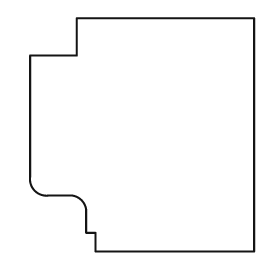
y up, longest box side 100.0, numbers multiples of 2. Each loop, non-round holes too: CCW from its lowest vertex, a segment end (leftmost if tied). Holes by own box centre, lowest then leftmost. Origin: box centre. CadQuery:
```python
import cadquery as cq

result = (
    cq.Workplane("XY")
    .moveTo(-20.0, -50.0)
    .lineTo(48.0, -50.0)
    .lineTo(48.0, 50.0)
    .lineTo(-28.0, 50.0)
    .lineTo(-28.0, 34.0)
    .lineTo(-48.0, 34.0)
    .lineTo(-48.0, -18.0)
    .threePointArc((-46.0, -24.0), (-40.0, -26.0))
    .lineTo(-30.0, -26.0)
    .threePointArc((-26.0, -28.0), (-24.0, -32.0))
    .lineTo(-24.0, -42.0)
    .lineTo(-20.0, -42.0)
    .close()
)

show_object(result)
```